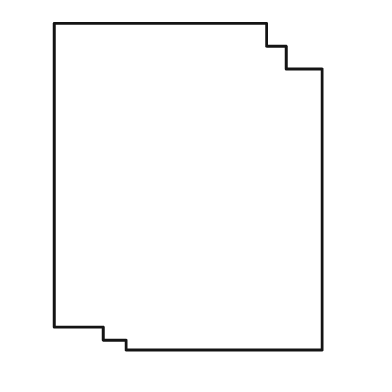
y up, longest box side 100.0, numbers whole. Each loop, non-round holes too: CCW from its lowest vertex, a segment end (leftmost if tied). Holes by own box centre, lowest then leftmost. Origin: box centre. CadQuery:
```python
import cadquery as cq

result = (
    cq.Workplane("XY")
    .moveTo(-19.0, -50.0)
    .lineTo(41.0, -50.0)
    .lineTo(41.0, 36.0)
    .lineTo(30.0, 36.0)
    .lineTo(30.0, 43.0)
    .lineTo(24.0, 43.0)
    .lineTo(24.0, 50.0)
    .lineTo(-41.0, 50.0)
    .lineTo(-41.0, -43.0)
    .lineTo(-26.0, -43.0)
    .lineTo(-26.0, -47.0)
    .lineTo(-19.0, -47.0)
    .close()
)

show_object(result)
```